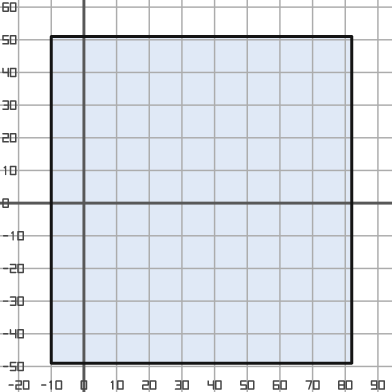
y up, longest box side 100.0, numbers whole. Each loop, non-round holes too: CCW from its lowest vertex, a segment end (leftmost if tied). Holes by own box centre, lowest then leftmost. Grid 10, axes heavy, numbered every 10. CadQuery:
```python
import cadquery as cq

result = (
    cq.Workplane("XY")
    .moveTo(-10.0, -49.0)
    .lineTo(82.0, -49.0)
    .lineTo(82.0, 51.0)
    .lineTo(-10.0, 51.0)
    .close()
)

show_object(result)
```